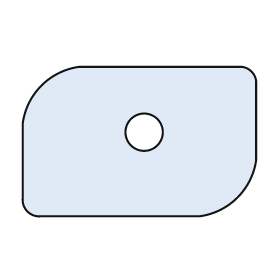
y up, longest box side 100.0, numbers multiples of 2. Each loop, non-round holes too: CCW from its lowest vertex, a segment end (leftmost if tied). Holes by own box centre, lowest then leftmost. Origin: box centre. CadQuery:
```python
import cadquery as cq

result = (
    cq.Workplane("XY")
    .moveTo(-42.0, -32.0)
    .lineTo(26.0, -32.0)
    .threePointArc((42.0, -24.0), (50.0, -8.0))
    .lineTo(50.0, 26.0)
    .threePointArc((48.0, 30.0), (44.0, 32.0))
    .lineTo(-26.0, 32.0)
    .threePointArc((-42.0, 24.0), (-50.0, 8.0))
    .lineTo(-50.0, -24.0)
    .threePointArc((-48.0, -30.0), (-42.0, -32.0))
    .close()
    .moveTo(2.0, 4.0)
    .circle(8.0)
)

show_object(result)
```